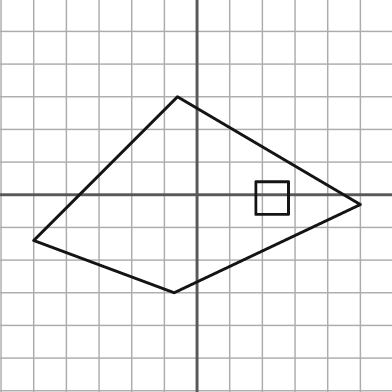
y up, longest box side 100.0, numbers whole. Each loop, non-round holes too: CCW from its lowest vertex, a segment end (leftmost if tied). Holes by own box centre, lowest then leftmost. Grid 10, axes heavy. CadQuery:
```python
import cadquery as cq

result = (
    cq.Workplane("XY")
    .moveTo(-7.0, -30.0)
    .lineTo(50.0, -3.0)
    .lineTo(-6.0, 30.0)
    .lineTo(-50.0, -14.0)
    .close()
    .moveTo(18.0, -6.0)
    .lineTo(28.0, -6.0)
    .lineTo(28.0, 4.0)
    .lineTo(18.0, 4.0)
    .close()
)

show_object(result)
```